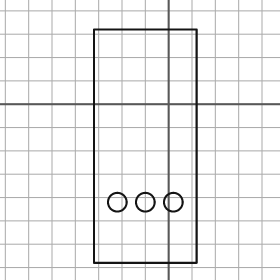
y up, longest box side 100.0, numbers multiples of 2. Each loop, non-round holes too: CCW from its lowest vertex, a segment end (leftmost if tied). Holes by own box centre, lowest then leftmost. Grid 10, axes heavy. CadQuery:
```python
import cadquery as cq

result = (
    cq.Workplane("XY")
    .moveTo(-32.0, -68.0)
    .lineTo(12.0, -68.0)
    .lineTo(12.0, 32.0)
    .lineTo(-32.0, 32.0)
    .close()
    .moveTo(-22.0, -42.0)
    .circle(4.0)
    .moveTo(-10.0, -42.0)
    .circle(4.0)
    .moveTo(2.0, -42.0)
    .circle(4.0)
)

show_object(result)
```